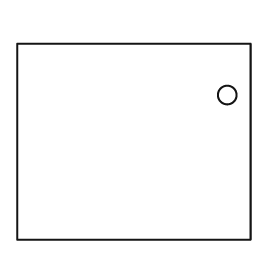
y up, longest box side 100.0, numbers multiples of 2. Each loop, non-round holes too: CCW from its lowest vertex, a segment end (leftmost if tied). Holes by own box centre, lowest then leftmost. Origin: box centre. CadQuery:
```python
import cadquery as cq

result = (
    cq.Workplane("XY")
    .moveTo(-50.0, -42.0)
    .lineTo(50.0, -42.0)
    .lineTo(50.0, 42.0)
    .lineTo(-50.0, 42.0)
    .close()
    .moveTo(40.0, 20.0)
    .circle(4.0)
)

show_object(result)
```